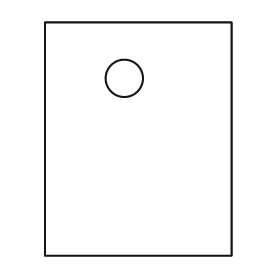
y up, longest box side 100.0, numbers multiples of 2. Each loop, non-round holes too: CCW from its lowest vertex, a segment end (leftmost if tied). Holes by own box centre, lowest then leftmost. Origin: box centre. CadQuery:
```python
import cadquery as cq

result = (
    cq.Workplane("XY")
    .moveTo(-40.0, -50.0)
    .lineTo(40.0, -50.0)
    .lineTo(40.0, 50.0)
    .lineTo(-40.0, 50.0)
    .close()
    .moveTo(-6.0, 26.0)
    .circle(8.0)
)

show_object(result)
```